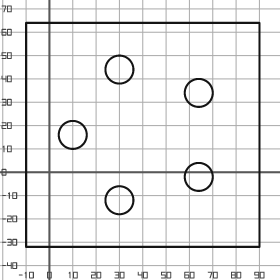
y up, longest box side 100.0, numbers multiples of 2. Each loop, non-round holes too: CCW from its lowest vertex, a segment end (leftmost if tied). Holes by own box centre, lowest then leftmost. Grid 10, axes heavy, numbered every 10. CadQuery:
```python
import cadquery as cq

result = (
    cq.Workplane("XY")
    .moveTo(-10.0, -32.0)
    .lineTo(90.0, -32.0)
    .lineTo(90.0, 64.0)
    .lineTo(-10.0, 64.0)
    .close()
    .moveTo(30.0, -12.0)
    .circle(6.0)
    .moveTo(64.0, -2.0)
    .circle(6.0)
    .moveTo(10.0, 16.0)
    .circle(6.0)
    .moveTo(64.0, 34.0)
    .circle(6.0)
    .moveTo(30.0, 44.0)
    .circle(6.0)
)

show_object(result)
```